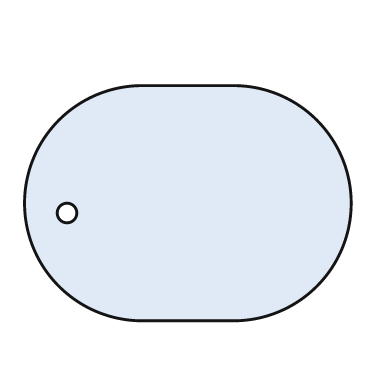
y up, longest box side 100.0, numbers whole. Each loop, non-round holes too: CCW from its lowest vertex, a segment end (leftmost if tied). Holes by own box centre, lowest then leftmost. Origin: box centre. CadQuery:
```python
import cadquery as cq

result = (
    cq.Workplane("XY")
    .moveTo(-14.0, -36.0)
    .lineTo(14.0, -36.0)
    .threePointArc((50.0, 0.0), (14.0, 36.0))
    .lineTo(-14.0, 36.0)
    .threePointArc((-50.0, 0.0), (-14.0, -36.0))
    .close()
    .moveTo(-37.0, -3.0)
    .circle(3.0)
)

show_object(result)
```